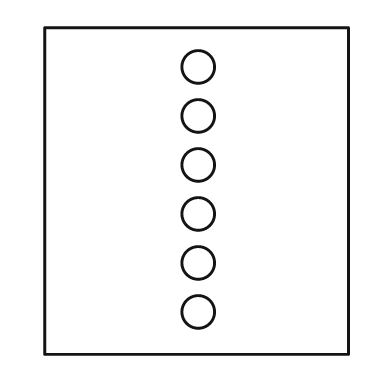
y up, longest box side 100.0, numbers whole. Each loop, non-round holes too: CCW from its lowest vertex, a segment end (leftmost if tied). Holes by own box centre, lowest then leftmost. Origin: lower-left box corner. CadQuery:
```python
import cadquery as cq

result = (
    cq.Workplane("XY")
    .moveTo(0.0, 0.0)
    .lineTo(93.0, 0.0)
    .lineTo(93.0, 100.0)
    .lineTo(0.0, 100.0)
    .close()
    .moveTo(47.0, 13.0)
    .circle(5.0)
    .moveTo(47.0, 28.0)
    .circle(5.0)
    .moveTo(47.0, 43.0)
    .circle(5.0)
    .moveTo(47.0, 58.0)
    .circle(5.0)
    .moveTo(47.0, 73.0)
    .circle(5.0)
    .moveTo(47.0, 88.0)
    .circle(5.0)
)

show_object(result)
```